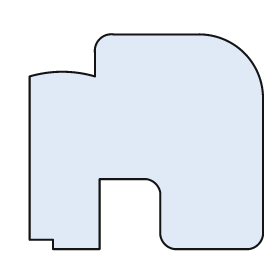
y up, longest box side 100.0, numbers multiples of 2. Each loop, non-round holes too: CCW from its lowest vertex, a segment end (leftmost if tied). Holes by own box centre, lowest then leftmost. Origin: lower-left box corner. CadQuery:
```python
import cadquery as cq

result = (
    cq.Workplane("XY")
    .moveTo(10.0, 0.0)
    .lineTo(30.0, 0.0)
    .lineTo(30.0, 30.0)
    .lineTo(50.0, 30.0)
    .threePointArc((54.0, 28.0), (56.0, 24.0))
    .lineTo(56.0, 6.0)
    .threePointArc((58.0, 2.0), (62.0, 0.0))
    .lineTo(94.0, 0.0)
    .threePointArc((98.0, 2.0), (100.0, 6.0))
    .lineTo(100.0, 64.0)
    .threePointArc((92.0, 84.0), (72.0, 92.0))
    .lineTo(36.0, 92.0)
    .threePointArc((30.0, 90.0), (28.0, 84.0))
    .lineTo(28.0, 74.0)
    .threePointArc((14.0, 76.0), (0.0, 74.0))
    .lineTo(0.0, 4.0)
    .lineTo(10.0, 4.0)
    .close()
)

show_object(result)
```